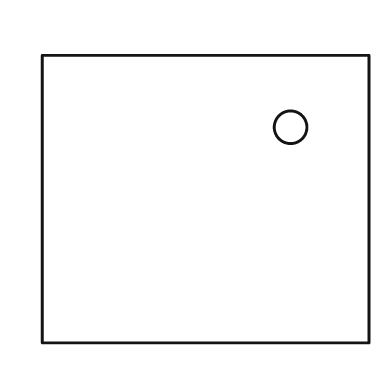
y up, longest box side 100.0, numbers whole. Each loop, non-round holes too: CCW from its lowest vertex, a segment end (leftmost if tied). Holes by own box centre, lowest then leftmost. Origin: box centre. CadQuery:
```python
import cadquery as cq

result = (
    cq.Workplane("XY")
    .moveTo(-50.0, -44.0)
    .lineTo(50.0, -44.0)
    .lineTo(50.0, 44.0)
    .lineTo(-50.0, 44.0)
    .close()
    .moveTo(26.0, 22.0)
    .circle(5.0)
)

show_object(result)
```